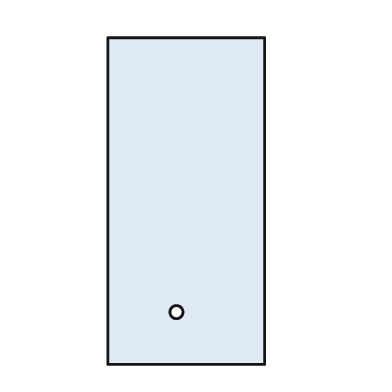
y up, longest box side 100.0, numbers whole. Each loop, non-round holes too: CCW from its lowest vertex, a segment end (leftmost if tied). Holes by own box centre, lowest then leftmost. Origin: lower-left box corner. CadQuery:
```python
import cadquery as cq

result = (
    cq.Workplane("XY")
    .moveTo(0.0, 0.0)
    .lineTo(48.0, 0.0)
    .lineTo(48.0, 100.0)
    .lineTo(0.0, 100.0)
    .close()
    .moveTo(21.0, 16.0)
    .circle(2.0)
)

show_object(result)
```